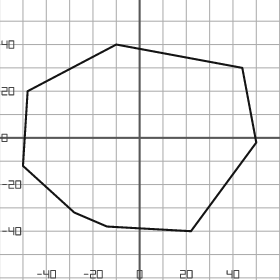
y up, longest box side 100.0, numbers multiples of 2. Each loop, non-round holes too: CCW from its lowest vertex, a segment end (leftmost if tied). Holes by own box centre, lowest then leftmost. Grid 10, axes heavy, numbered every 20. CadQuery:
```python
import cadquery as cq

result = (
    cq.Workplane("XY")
    .moveTo(22.0, -40.0)
    .lineTo(50.0, -2.0)
    .lineTo(44.0, 30.0)
    .lineTo(-10.0, 40.0)
    .lineTo(-48.0, 20.0)
    .lineTo(-50.0, -12.0)
    .lineTo(-28.0, -32.0)
    .lineTo(-14.0, -38.0)
    .close()
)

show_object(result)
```